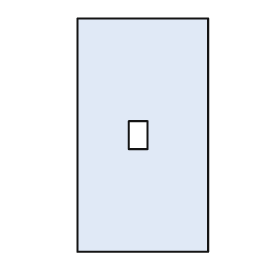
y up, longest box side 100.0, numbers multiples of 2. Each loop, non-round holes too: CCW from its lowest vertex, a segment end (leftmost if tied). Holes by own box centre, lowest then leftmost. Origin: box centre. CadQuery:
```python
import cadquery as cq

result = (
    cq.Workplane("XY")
    .moveTo(-28.0, -50.0)
    .lineTo(28.0, -50.0)
    .lineTo(28.0, 50.0)
    .lineTo(-28.0, 50.0)
    .close()
    .moveTo(-6.0, -6.0)
    .lineTo(2.0, -6.0)
    .lineTo(2.0, 6.0)
    .lineTo(-6.0, 6.0)
    .close()
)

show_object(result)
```